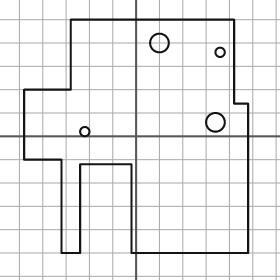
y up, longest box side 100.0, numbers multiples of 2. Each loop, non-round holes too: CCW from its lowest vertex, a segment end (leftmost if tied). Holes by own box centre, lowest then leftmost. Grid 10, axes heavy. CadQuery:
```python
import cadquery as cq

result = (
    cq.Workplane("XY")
    .moveTo(-32.0, -50.0)
    .lineTo(-24.0, -50.0)
    .lineTo(-24.0, -12.0)
    .lineTo(-2.0, -12.0)
    .lineTo(-2.0, -50.0)
    .lineTo(48.0, -50.0)
    .lineTo(48.0, 14.0)
    .lineTo(42.0, 14.0)
    .lineTo(42.0, 50.0)
    .lineTo(-28.0, 50.0)
    .lineTo(-28.0, 20.0)
    .lineTo(-48.0, 20.0)
    .lineTo(-48.0, -10.0)
    .lineTo(-32.0, -10.0)
    .close()
    .moveTo(-22.0, 2.0)
    .circle(2.0)
    .moveTo(34.0, 6.0)
    .circle(4.0)
    .moveTo(36.0, 36.0)
    .circle(2.0)
    .moveTo(10.0, 40.0)
    .circle(4.0)
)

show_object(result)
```